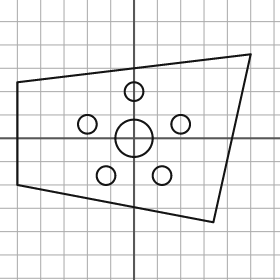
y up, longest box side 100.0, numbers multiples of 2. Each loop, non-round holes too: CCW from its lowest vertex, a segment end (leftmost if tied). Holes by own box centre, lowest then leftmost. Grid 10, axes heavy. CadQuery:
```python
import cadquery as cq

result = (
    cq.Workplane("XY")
    .moveTo(34.0, -36.0)
    .lineTo(50.0, 36.0)
    .lineTo(-50.0, 24.0)
    .lineTo(-50.0, -20.0)
    .close()
    .moveTo(-12.0, -16.0)
    .circle(4.0)
    .moveTo(12.0, -16.0)
    .circle(4.0)
    .moveTo(0.0, 0.0)
    .circle(8.0)
    .moveTo(-20.0, 6.0)
    .circle(4.0)
    .moveTo(20.0, 6.0)
    .circle(4.0)
    .moveTo(0.0, 20.0)
    .circle(4.0)
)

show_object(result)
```